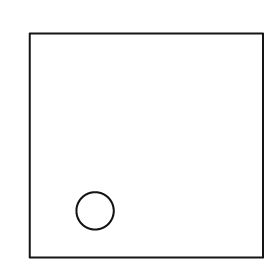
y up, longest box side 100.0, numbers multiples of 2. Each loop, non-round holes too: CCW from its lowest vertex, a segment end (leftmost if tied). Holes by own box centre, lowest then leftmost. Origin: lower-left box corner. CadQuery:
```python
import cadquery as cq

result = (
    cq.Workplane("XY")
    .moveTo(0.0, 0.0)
    .lineTo(100.0, 0.0)
    .lineTo(100.0, 96.0)
    .lineTo(0.0, 96.0)
    .close()
    .moveTo(28.0, 20.0)
    .circle(8.0)
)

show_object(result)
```